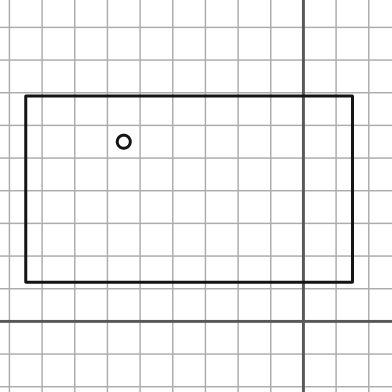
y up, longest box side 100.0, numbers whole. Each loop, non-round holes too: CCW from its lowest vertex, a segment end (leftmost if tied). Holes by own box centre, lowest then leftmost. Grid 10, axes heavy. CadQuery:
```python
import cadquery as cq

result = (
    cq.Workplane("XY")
    .moveTo(-85.0, 12.0)
    .lineTo(15.0, 12.0)
    .lineTo(15.0, 69.0)
    .lineTo(-85.0, 69.0)
    .close()
    .moveTo(-55.0, 55.0)
    .circle(2.0)
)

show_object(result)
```